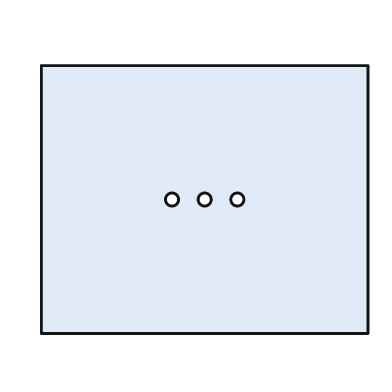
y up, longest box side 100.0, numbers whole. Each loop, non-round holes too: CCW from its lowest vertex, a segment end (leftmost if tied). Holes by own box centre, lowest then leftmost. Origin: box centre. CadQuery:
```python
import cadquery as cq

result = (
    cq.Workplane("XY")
    .moveTo(-50.0, -41.0)
    .lineTo(50.0, -41.0)
    .lineTo(50.0, 41.0)
    .lineTo(-50.0, 41.0)
    .close()
    .moveTo(-10.0, 0.0)
    .circle(2.0)
    .moveTo(0.0, 0.0)
    .circle(2.0)
    .moveTo(10.0, 0.0)
    .circle(2.0)
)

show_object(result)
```